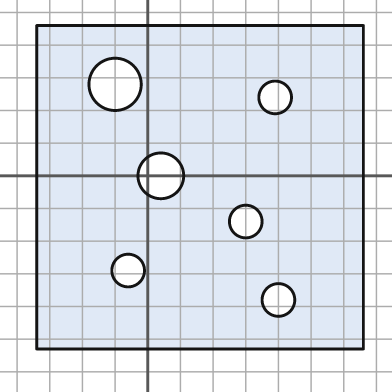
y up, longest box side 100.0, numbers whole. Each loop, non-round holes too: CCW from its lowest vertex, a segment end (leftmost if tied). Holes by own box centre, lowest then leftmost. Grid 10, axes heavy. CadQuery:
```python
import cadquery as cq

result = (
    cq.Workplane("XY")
    .moveTo(-34.0, -53.0)
    .lineTo(66.0, -53.0)
    .lineTo(66.0, 46.0)
    .lineTo(-34.0, 46.0)
    .close()
    .moveTo(40.0, -38.0)
    .circle(5.0)
    .moveTo(-6.0, -29.0)
    .circle(5.0)
    .moveTo(30.0, -14.0)
    .circle(5.0)
    .moveTo(4.0, 0.0)
    .circle(7.0)
    .moveTo(39.0, 24.0)
    .circle(5.0)
    .moveTo(-10.0, 28.0)
    .circle(8.0)
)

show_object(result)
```